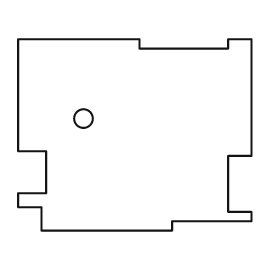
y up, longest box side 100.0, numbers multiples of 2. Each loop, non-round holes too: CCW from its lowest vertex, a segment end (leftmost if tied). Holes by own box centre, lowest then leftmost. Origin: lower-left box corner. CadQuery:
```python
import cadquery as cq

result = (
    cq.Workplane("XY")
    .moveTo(10.0, 0.0)
    .lineTo(66.0, 0.0)
    .lineTo(66.0, 4.0)
    .lineTo(100.0, 4.0)
    .lineTo(100.0, 8.0)
    .lineTo(90.0, 8.0)
    .lineTo(90.0, 32.0)
    .lineTo(100.0, 32.0)
    .lineTo(100.0, 82.0)
    .lineTo(90.0, 82.0)
    .lineTo(90.0, 78.0)
    .lineTo(52.0, 78.0)
    .lineTo(52.0, 82.0)
    .lineTo(0.0, 82.0)
    .lineTo(0.0, 34.0)
    .lineTo(12.0, 34.0)
    .lineTo(12.0, 16.0)
    .lineTo(0.0, 16.0)
    .lineTo(0.0, 10.0)
    .lineTo(10.0, 10.0)
    .close()
    .moveTo(28.0, 48.0)
    .circle(4.0)
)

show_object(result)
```